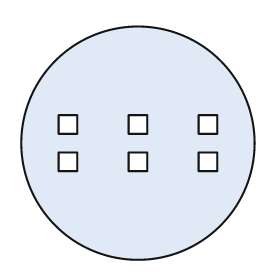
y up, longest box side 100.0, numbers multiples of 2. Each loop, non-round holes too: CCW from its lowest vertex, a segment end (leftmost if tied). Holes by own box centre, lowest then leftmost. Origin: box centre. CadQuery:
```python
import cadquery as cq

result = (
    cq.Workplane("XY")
    .moveTo(0.0, 0.0)
    .circle(50.0)
    .moveTo(-34.0, -12.0)
    .lineTo(-26.0, -12.0)
    .lineTo(-26.0, -4.0)
    .lineTo(-34.0, -4.0)
    .close()
    .moveTo(-4.0, -12.0)
    .lineTo(4.0, -12.0)
    .lineTo(4.0, -4.0)
    .lineTo(-4.0, -4.0)
    .close()
    .moveTo(26.0, -12.0)
    .lineTo(34.0, -12.0)
    .lineTo(34.0, -4.0)
    .lineTo(26.0, -4.0)
    .close()
    .moveTo(-34.0, 4.0)
    .lineTo(-26.0, 4.0)
    .lineTo(-26.0, 12.0)
    .lineTo(-34.0, 12.0)
    .close()
    .moveTo(-4.0, 4.0)
    .lineTo(4.0, 4.0)
    .lineTo(4.0, 12.0)
    .lineTo(-4.0, 12.0)
    .close()
    .moveTo(26.0, 4.0)
    .lineTo(34.0, 4.0)
    .lineTo(34.0, 12.0)
    .lineTo(26.0, 12.0)
    .close()
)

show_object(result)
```